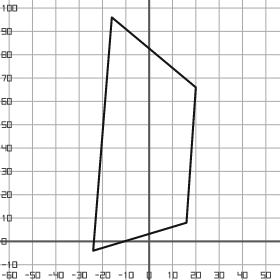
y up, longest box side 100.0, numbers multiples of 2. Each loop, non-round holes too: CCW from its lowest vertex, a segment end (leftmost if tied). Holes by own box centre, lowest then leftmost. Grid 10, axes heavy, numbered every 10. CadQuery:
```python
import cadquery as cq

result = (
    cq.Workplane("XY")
    .moveTo(-24.0, -4.0)
    .lineTo(16.0, 8.0)
    .lineTo(20.0, 66.0)
    .lineTo(-16.0, 96.0)
    .close()
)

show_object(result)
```